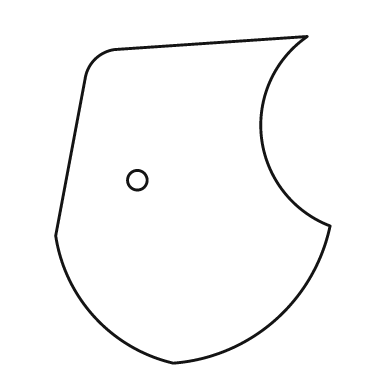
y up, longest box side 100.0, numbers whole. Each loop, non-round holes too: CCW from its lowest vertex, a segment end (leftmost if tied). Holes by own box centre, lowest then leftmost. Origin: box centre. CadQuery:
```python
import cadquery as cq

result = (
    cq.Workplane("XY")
    .moveTo(-6.0, -50.0)
    .threePointArc((25.0, -37.0), (42.0, -8.0))
    .threePointArc((21.0, 19.0), (35.0, 50.0))
    .lineTo(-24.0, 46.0)
    .threePointArc((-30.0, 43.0), (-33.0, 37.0))
    .lineTo(-42.0, -11.0)
    .threePointArc((-30.0, -36.0), (-6.0, -50.0))
    .close()
    .moveTo(-17.0, 6.0)
    .circle(3.0)
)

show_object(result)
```